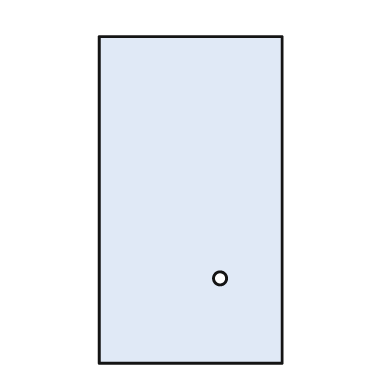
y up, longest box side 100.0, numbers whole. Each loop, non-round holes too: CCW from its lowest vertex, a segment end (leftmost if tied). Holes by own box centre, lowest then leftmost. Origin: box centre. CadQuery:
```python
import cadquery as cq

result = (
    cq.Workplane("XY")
    .moveTo(-28.0, -50.0)
    .lineTo(28.0, -50.0)
    .lineTo(28.0, 50.0)
    .lineTo(-28.0, 50.0)
    .close()
    .moveTo(9.0, -24.0)
    .circle(2.0)
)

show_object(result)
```